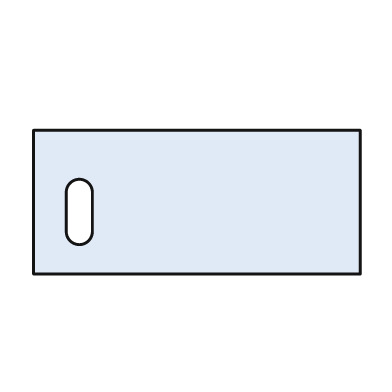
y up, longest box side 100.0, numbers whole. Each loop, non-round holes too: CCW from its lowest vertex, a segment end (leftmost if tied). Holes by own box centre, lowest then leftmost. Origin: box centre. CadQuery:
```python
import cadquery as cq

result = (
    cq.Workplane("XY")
    .moveTo(-50.0, -22.0)
    .lineTo(50.0, -22.0)
    .lineTo(50.0, 22.0)
    .lineTo(-50.0, 22.0)
    .close()
    .moveTo(-40.0, -9.0)
    .threePointArc((-36.0, -13.0), (-32.0, -9.0))
    .lineTo(-32.0, 3.0)
    .threePointArc((-36.0, 7.0), (-40.0, 3.0))
    .close()
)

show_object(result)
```